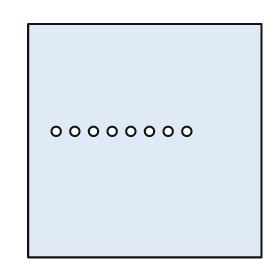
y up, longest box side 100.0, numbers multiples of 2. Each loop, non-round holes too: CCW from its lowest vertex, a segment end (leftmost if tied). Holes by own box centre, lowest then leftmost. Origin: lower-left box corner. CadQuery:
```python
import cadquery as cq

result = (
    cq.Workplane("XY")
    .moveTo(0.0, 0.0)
    .lineTo(100.0, 0.0)
    .lineTo(100.0, 100.0)
    .lineTo(0.0, 100.0)
    .close()
    .moveTo(12.0, 54.0)
    .circle(2.0)
    .moveTo(20.0, 54.0)
    .circle(2.0)
    .moveTo(28.0, 54.0)
    .circle(2.0)
    .moveTo(36.0, 54.0)
    .circle(2.0)
    .moveTo(44.0, 54.0)
    .circle(2.0)
    .moveTo(52.0, 54.0)
    .circle(2.0)
    .moveTo(60.0, 54.0)
    .circle(2.0)
    .moveTo(68.0, 54.0)
    .circle(2.0)
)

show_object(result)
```